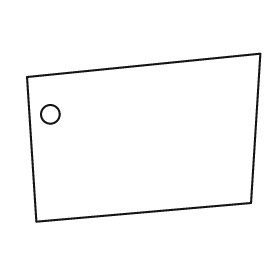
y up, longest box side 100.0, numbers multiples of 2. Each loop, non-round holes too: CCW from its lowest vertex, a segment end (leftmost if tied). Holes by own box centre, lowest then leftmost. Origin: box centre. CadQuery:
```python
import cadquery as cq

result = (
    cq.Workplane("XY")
    .moveTo(-46.0, -36.0)
    .lineTo(46.0, -28.0)
    .lineTo(50.0, 36.0)
    .lineTo(-50.0, 26.0)
    .close()
    .moveTo(-40.0, 10.0)
    .circle(4.0)
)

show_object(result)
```